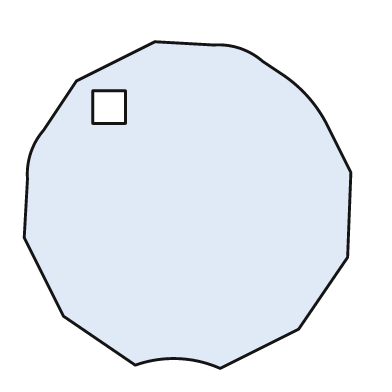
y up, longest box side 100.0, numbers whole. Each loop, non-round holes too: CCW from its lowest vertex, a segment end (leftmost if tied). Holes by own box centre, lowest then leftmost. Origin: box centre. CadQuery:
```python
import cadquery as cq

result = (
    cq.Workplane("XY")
    .moveTo(10.0, -50.0)
    .lineTo(34.0, -38.0)
    .lineTo(49.0, -16.0)
    .lineTo(50.0, 10.0)
    .lineTo(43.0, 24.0)
    .threePointArc((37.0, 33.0), (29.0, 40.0))
    .lineTo(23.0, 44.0)
    .threePointArc((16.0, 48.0), (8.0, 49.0))
    .lineTo(-10.0, 50.0)
    .lineTo(-34.0, 38.0)
    .lineTo(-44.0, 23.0)
    .threePointArc((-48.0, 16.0), (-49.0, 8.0))
    .lineTo(-50.0, -10.0)
    .lineTo(-38.0, -34.0)
    .lineTo(-16.0, -49.0)
    .threePointArc((-3.0, -47.0), (10.0, -50.0))
    .close()
    .moveTo(-29.0, 25.0)
    .lineTo(-19.0, 25.0)
    .lineTo(-19.0, 35.0)
    .lineTo(-29.0, 35.0)
    .close()
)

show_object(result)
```